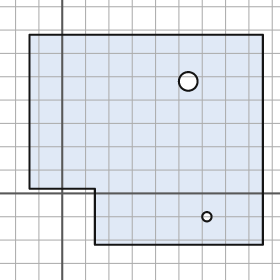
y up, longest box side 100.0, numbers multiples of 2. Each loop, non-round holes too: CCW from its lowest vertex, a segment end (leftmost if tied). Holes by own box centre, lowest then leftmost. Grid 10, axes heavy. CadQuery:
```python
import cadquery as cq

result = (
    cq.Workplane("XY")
    .moveTo(14.0, -22.0)
    .lineTo(86.0, -22.0)
    .lineTo(86.0, 68.0)
    .lineTo(-14.0, 68.0)
    .lineTo(-14.0, 2.0)
    .lineTo(14.0, 2.0)
    .close()
    .moveTo(62.0, -10.0)
    .circle(2.0)
    .moveTo(54.0, 48.0)
    .circle(4.0)
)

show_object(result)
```